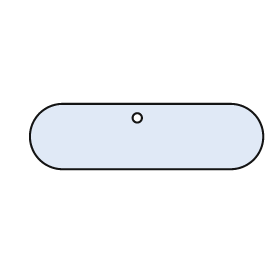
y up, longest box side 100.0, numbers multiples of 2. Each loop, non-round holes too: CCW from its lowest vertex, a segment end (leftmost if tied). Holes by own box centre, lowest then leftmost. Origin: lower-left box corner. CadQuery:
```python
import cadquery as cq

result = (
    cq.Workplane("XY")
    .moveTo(14.0, 0.0)
    .lineTo(86.0, 0.0)
    .threePointArc((100.0, 14.0), (86.0, 28.0))
    .lineTo(14.0, 28.0)
    .threePointArc((0.0, 14.0), (14.0, 0.0))
    .close()
    .moveTo(46.0, 22.0)
    .circle(2.0)
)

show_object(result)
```